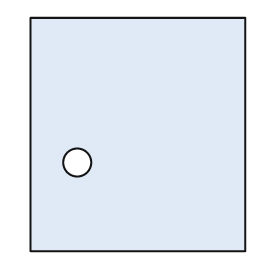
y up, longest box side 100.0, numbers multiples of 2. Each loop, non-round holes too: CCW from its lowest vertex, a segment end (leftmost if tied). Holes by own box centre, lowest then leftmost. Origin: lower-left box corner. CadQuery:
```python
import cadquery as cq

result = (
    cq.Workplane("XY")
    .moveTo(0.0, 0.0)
    .lineTo(92.0, 0.0)
    .lineTo(92.0, 100.0)
    .lineTo(0.0, 100.0)
    .close()
    .moveTo(20.0, 38.0)
    .circle(6.0)
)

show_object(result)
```